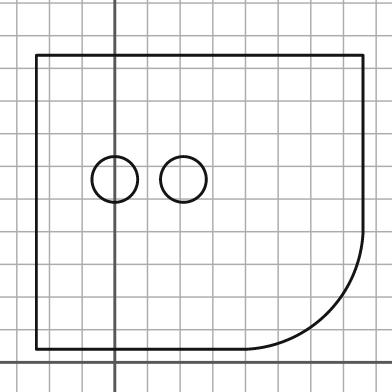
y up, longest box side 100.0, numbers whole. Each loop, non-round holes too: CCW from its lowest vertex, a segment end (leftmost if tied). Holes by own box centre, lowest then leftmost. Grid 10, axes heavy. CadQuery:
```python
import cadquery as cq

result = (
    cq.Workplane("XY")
    .moveTo(-24.0, 4.0)
    .lineTo(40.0, 4.0)
    .threePointArc((65.0, 15.0), (76.0, 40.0))
    .lineTo(76.0, 94.0)
    .lineTo(-24.0, 94.0)
    .close()
    .moveTo(0.0, 56.0)
    .circle(7.0)
    .moveTo(21.0, 56.0)
    .circle(7.0)
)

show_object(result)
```